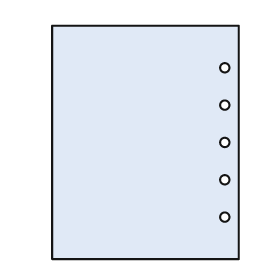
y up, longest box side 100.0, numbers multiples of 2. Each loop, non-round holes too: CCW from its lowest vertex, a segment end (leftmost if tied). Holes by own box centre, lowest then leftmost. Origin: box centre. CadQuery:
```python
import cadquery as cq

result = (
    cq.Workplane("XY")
    .moveTo(-40.0, -50.0)
    .lineTo(40.0, -50.0)
    .lineTo(40.0, 50.0)
    .lineTo(-40.0, 50.0)
    .close()
    .moveTo(34.0, -32.0)
    .circle(2.0)
    .moveTo(34.0, -16.0)
    .circle(2.0)
    .moveTo(34.0, 0.0)
    .circle(2.0)
    .moveTo(34.0, 16.0)
    .circle(2.0)
    .moveTo(34.0, 32.0)
    .circle(2.0)
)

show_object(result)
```